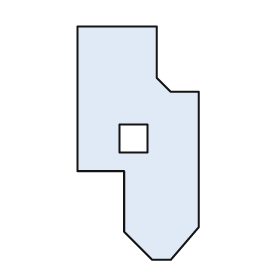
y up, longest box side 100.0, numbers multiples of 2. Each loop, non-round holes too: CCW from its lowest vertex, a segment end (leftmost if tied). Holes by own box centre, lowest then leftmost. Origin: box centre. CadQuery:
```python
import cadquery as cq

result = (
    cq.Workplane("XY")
    .moveTo(6.0, -50.0)
    .lineTo(14.0, -50.0)
    .lineTo(26.0, -36.0)
    .lineTo(26.0, 22.0)
    .lineTo(14.0, 22.0)
    .lineTo(8.0, 28.0)
    .lineTo(8.0, 50.0)
    .lineTo(-26.0, 50.0)
    .lineTo(-26.0, -12.0)
    .lineTo(-6.0, -12.0)
    .lineTo(-6.0, -38.0)
    .close()
    .moveTo(-8.0, -4.0)
    .lineTo(4.0, -4.0)
    .lineTo(4.0, 8.0)
    .lineTo(-8.0, 8.0)
    .close()
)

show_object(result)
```